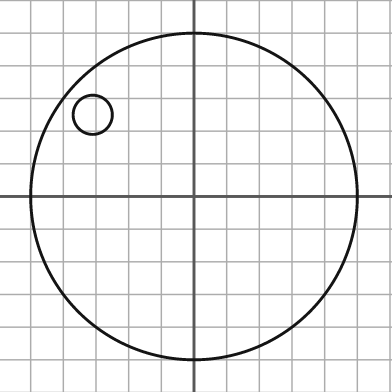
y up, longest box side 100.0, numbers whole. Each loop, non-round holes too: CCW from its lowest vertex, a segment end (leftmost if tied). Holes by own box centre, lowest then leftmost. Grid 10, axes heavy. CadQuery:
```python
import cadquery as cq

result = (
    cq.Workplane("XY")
    .moveTo(0.0, 0.0)
    .circle(50.0)
    .moveTo(-31.0, 25.0)
    .circle(6.0)
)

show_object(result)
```